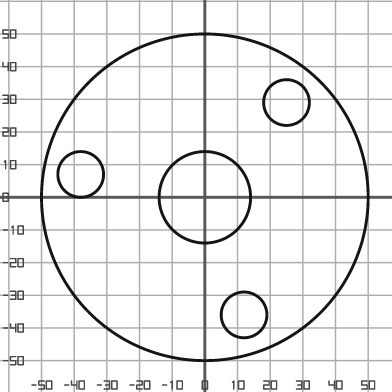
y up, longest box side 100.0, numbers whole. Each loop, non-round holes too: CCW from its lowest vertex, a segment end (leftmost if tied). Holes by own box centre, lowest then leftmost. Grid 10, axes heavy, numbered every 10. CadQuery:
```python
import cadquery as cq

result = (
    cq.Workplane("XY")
    .moveTo(0.0, 0.0)
    .circle(50.0)
    .moveTo(12.0, -36.0)
    .circle(7.0)
    .moveTo(0.0, 0.0)
    .circle(14.0)
    .moveTo(-38.0, 7.0)
    .circle(7.0)
    .moveTo(25.0, 29.0)
    .circle(7.0)
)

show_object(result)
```